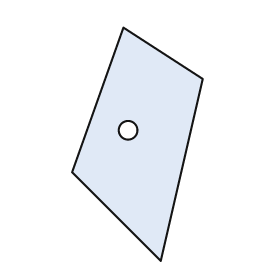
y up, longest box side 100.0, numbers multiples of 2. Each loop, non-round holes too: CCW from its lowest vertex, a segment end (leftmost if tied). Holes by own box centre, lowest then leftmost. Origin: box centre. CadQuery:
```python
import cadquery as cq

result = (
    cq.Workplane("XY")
    .moveTo(10.0, -50.0)
    .lineTo(28.0, 28.0)
    .lineTo(-6.0, 50.0)
    .lineTo(-28.0, -12.0)
    .close()
    .moveTo(-4.0, 6.0)
    .circle(4.0)
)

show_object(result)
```